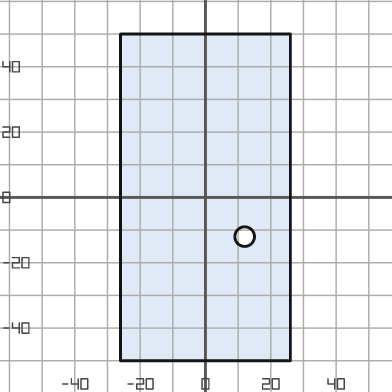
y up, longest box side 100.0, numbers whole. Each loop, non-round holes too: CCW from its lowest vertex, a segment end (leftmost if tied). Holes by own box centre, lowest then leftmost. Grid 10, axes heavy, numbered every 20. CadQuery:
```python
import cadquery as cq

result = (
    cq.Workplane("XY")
    .moveTo(-26.0, -50.0)
    .lineTo(26.0, -50.0)
    .lineTo(26.0, 50.0)
    .lineTo(-26.0, 50.0)
    .close()
    .moveTo(12.0, -12.0)
    .circle(3.0)
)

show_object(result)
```